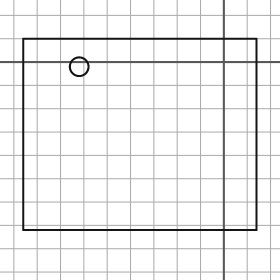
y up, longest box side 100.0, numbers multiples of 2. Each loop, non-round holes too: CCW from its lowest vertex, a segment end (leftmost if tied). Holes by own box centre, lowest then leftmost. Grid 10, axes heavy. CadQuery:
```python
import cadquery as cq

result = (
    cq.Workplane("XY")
    .moveTo(-86.0, -72.0)
    .lineTo(14.0, -72.0)
    .lineTo(14.0, 10.0)
    .lineTo(-86.0, 10.0)
    .close()
    .moveTo(-62.0, -2.0)
    .circle(4.0)
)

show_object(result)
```